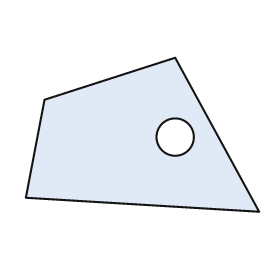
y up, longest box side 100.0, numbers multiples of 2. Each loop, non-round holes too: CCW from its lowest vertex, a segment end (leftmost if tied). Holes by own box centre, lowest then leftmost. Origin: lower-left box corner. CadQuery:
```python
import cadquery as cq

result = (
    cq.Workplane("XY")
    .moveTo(100.0, 0.0)
    .lineTo(64.0, 66.0)
    .lineTo(8.0, 48.0)
    .lineTo(0.0, 6.0)
    .close()
    .moveTo(64.0, 32.0)
    .circle(8.0)
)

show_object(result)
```